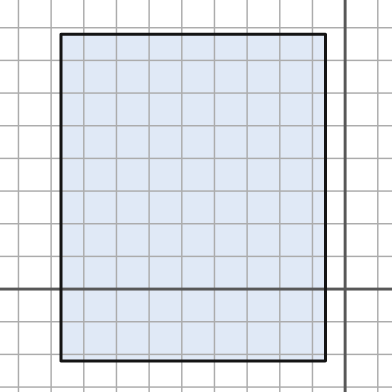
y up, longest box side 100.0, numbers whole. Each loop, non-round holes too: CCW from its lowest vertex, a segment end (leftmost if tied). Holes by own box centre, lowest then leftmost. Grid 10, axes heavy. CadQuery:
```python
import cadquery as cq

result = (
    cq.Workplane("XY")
    .moveTo(-87.0, -22.0)
    .lineTo(-6.0, -22.0)
    .lineTo(-6.0, 78.0)
    .lineTo(-87.0, 78.0)
    .close()
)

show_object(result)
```